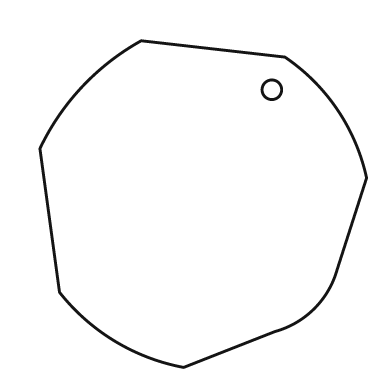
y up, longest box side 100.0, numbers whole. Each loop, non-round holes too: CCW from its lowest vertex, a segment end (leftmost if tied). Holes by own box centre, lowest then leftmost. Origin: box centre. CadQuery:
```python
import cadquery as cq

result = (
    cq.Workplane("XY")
    .moveTo(-6.0, -50.0)
    .lineTo(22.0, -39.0)
    .threePointArc((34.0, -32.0), (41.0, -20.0))
    .lineTo(50.0, 8.0)
    .threePointArc((41.0, 29.0), (25.0, 45.0))
    .lineTo(-19.0, 50.0)
    .threePointArc((-37.0, 36.0), (-50.0, 17.0))
    .lineTo(-44.0, -27.0)
    .threePointArc((-27.0, -42.0), (-6.0, -50.0))
    .close()
    .moveTo(21.0, 35.0)
    .circle(3.0)
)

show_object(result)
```